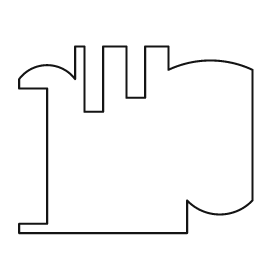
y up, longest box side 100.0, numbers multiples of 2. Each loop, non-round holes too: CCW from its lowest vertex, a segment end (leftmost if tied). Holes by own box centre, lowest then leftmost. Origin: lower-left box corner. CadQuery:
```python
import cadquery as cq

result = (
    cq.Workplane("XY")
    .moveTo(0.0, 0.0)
    .lineTo(72.0, 0.0)
    .lineTo(72.0, 14.0)
    .threePointArc((86.0, 8.0), (100.0, 14.0))
    .lineTo(100.0, 70.0)
    .threePointArc((82.0, 74.0), (64.0, 70.0))
    .lineTo(64.0, 80.0)
    .lineTo(54.0, 80.0)
    .lineTo(54.0, 58.0)
    .lineTo(46.0, 58.0)
    .lineTo(46.0, 80.0)
    .lineTo(36.0, 80.0)
    .lineTo(36.0, 52.0)
    .lineTo(28.0, 52.0)
    .lineTo(28.0, 80.0)
    .lineTo(24.0, 80.0)
    .lineTo(24.0, 66.0)
    .threePointArc((12.0, 72.0), (0.0, 66.0))
    .lineTo(0.0, 62.0)
    .lineTo(12.0, 62.0)
    .lineTo(12.0, 4.0)
    .lineTo(0.0, 4.0)
    .close()
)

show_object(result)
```